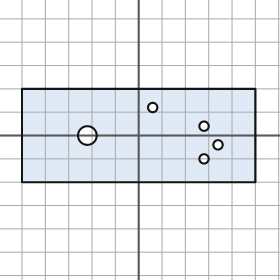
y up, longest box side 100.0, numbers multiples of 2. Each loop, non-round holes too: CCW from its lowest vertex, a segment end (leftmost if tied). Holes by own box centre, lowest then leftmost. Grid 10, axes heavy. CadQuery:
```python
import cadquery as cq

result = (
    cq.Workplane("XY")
    .moveTo(-50.0, -20.0)
    .lineTo(50.0, -20.0)
    .lineTo(50.0, 20.0)
    .lineTo(-50.0, 20.0)
    .close()
    .moveTo(28.0, -10.0)
    .circle(2.0)
    .moveTo(34.0, -4.0)
    .circle(2.0)
    .moveTo(-22.0, 0.0)
    .circle(4.0)
    .moveTo(28.0, 4.0)
    .circle(2.0)
    .moveTo(6.0, 12.0)
    .circle(2.0)
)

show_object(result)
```